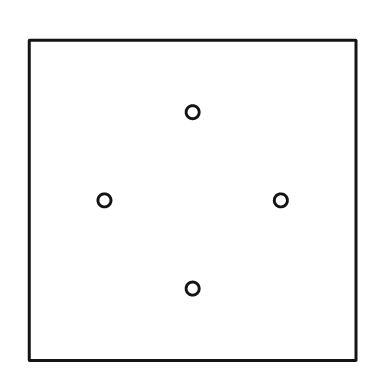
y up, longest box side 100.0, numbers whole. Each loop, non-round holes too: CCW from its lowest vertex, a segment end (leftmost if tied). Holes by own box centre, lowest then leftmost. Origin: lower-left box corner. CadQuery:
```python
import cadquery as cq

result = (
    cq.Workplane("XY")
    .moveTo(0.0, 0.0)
    .lineTo(100.0, 0.0)
    .lineTo(100.0, 98.0)
    .lineTo(0.0, 98.0)
    .close()
    .moveTo(50.0, 22.0)
    .circle(2.0)
    .moveTo(23.0, 49.0)
    .circle(2.0)
    .moveTo(77.0, 49.0)
    .circle(2.0)
    .moveTo(50.0, 76.0)
    .circle(2.0)
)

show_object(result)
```